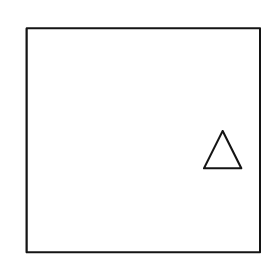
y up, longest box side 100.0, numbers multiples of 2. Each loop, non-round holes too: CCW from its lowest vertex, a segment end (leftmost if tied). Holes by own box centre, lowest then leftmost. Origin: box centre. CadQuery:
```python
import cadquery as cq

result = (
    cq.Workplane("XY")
    .moveTo(-50.0, -48.0)
    .lineTo(50.0, -48.0)
    .lineTo(50.0, 48.0)
    .lineTo(-50.0, 48.0)
    .close()
    .moveTo(26.0, -12.0)
    .lineTo(42.0, -12.0)
    .lineTo(34.0, 4.0)
    .close()
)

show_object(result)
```